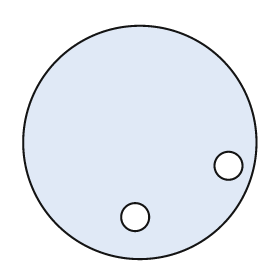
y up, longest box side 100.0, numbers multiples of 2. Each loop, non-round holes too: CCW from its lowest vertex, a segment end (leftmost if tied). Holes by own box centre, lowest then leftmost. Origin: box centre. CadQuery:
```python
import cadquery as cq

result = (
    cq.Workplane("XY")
    .moveTo(0.0, 0.0)
    .circle(50.0)
    .moveTo(-2.0, -32.0)
    .circle(6.0)
    .moveTo(38.0, -10.0)
    .circle(6.0)
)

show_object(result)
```